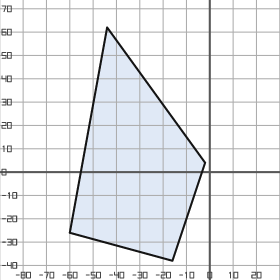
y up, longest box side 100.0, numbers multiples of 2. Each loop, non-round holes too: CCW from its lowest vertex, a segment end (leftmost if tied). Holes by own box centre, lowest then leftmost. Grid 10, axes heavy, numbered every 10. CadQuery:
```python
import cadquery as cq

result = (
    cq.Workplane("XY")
    .moveTo(-16.0, -38.0)
    .lineTo(-2.0, 4.0)
    .lineTo(-44.0, 62.0)
    .lineTo(-60.0, -26.0)
    .close()
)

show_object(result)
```